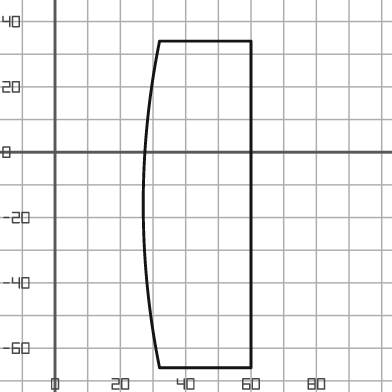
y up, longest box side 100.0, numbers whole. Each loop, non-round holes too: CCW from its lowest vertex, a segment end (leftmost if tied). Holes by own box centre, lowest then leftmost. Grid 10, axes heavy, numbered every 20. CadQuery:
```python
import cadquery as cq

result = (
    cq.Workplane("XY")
    .moveTo(32.0, -66.0)
    .lineTo(60.0, -66.0)
    .lineTo(60.0, 34.0)
    .lineTo(32.0, 34.0)
    .threePointArc((27.0, -16.0), (32.0, -66.0))
    .close()
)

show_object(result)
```